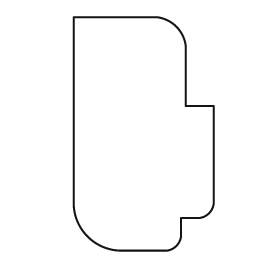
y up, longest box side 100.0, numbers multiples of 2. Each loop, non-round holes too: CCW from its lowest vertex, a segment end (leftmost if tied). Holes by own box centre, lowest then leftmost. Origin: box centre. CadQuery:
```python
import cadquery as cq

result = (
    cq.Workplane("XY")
    .moveTo(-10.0, -50.0)
    .lineTo(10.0, -50.0)
    .threePointArc((14.0, -48.0), (16.0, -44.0))
    .lineTo(16.0, -36.0)
    .lineTo(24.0, -36.0)
    .threePointArc((28.0, -34.0), (30.0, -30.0))
    .lineTo(30.0, 12.0)
    .lineTo(18.0, 12.0)
    .lineTo(18.0, 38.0)
    .threePointArc((14.0, 46.0), (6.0, 50.0))
    .lineTo(-30.0, 50.0)
    .lineTo(-30.0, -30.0)
    .threePointArc((-24.0, -44.0), (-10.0, -50.0))
    .close()
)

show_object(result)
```